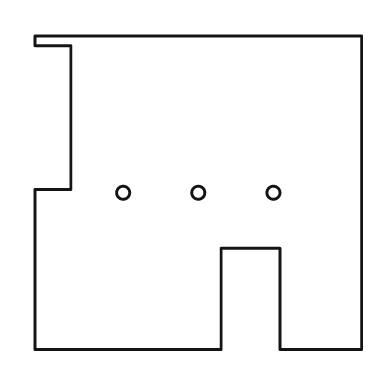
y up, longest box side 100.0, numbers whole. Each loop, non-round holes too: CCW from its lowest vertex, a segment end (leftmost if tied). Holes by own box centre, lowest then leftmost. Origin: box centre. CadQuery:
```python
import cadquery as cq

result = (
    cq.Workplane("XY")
    .moveTo(-50.0, -48.0)
    .lineTo(7.0, -48.0)
    .lineTo(7.0, -17.0)
    .lineTo(25.0, -17.0)
    .lineTo(25.0, -48.0)
    .lineTo(50.0, -48.0)
    .lineTo(50.0, 48.0)
    .lineTo(-50.0, 48.0)
    .lineTo(-50.0, 45.0)
    .lineTo(-39.0, 45.0)
    .lineTo(-39.0, 1.0)
    .lineTo(-50.0, 1.0)
    .close()
    .moveTo(-23.0, 0.0)
    .circle(2.0)
    .moveTo(0.0, 0.0)
    .circle(2.0)
    .moveTo(23.0, 0.0)
    .circle(2.0)
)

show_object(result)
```